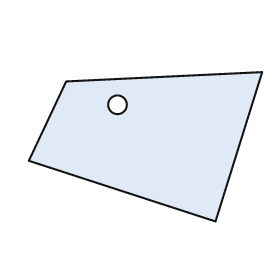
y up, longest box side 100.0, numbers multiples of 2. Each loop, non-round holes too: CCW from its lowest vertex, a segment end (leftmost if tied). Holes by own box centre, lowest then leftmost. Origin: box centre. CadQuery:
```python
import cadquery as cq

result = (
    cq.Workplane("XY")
    .moveTo(30.0, -32.0)
    .lineTo(50.0, 32.0)
    .lineTo(-34.0, 28.0)
    .lineTo(-50.0, -6.0)
    .close()
    .moveTo(-12.0, 18.0)
    .circle(4.0)
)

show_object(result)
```